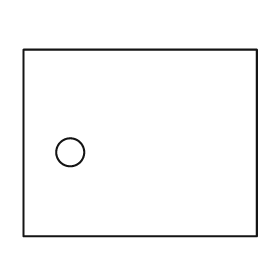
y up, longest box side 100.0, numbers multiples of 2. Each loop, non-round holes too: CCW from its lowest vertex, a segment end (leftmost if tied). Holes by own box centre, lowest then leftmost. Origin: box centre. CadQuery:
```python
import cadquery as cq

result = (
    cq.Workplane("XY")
    .moveTo(-50.0, -40.0)
    .lineTo(50.0, -40.0)
    .lineTo(50.0, 40.0)
    .lineTo(-50.0, 40.0)
    .close()
    .moveTo(-30.0, -4.0)
    .circle(6.0)
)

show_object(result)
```